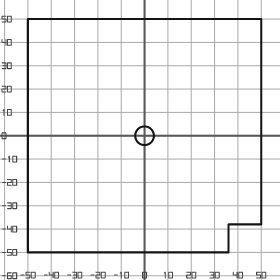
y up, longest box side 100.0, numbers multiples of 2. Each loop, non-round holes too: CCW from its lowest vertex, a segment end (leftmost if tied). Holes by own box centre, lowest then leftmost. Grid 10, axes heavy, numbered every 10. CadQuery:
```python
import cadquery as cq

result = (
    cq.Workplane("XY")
    .moveTo(-50.0, -50.0)
    .lineTo(36.0, -50.0)
    .lineTo(36.0, -38.0)
    .lineTo(50.0, -38.0)
    .lineTo(50.0, 50.0)
    .lineTo(-50.0, 50.0)
    .close()
    .moveTo(0.0, 0.0)
    .circle(4.0)
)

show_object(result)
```